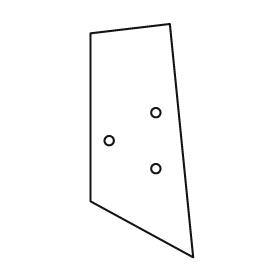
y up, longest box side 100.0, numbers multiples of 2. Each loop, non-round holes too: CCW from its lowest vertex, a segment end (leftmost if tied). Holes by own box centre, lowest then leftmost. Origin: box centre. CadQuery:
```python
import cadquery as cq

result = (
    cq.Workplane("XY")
    .moveTo(22.0, -50.0)
    .lineTo(12.0, 50.0)
    .lineTo(-22.0, 46.0)
    .lineTo(-22.0, -26.0)
    .close()
    .moveTo(6.0, -12.0)
    .circle(2.0)
    .moveTo(-14.0, 0.0)
    .circle(2.0)
    .moveTo(6.0, 12.0)
    .circle(2.0)
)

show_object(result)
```